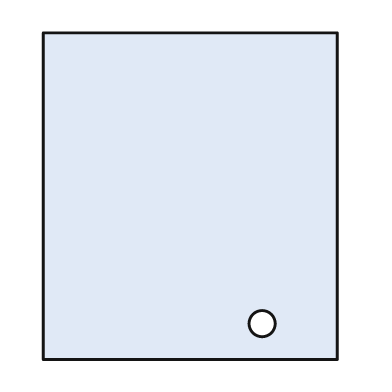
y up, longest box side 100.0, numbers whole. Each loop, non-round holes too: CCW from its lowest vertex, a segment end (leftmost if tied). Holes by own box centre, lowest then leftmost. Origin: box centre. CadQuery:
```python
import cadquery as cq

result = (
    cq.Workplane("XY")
    .moveTo(-45.0, -50.0)
    .lineTo(45.0, -50.0)
    .lineTo(45.0, 50.0)
    .lineTo(-45.0, 50.0)
    .close()
    .moveTo(22.0, -39.0)
    .circle(4.0)
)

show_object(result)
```